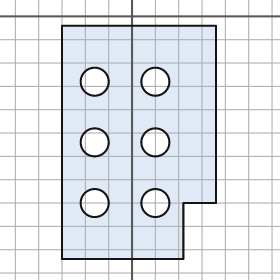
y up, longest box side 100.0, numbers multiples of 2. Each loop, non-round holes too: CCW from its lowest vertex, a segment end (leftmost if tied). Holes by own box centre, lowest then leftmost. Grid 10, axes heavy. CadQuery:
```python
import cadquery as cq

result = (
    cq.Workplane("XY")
    .moveTo(-30.0, -104.0)
    .lineTo(22.0, -104.0)
    .lineTo(22.0, -80.0)
    .lineTo(36.0, -80.0)
    .lineTo(36.0, -4.0)
    .lineTo(-30.0, -4.0)
    .close()
    .moveTo(-16.0, -80.0)
    .circle(6.0)
    .moveTo(10.0, -80.0)
    .circle(6.0)
    .moveTo(-16.0, -54.0)
    .circle(6.0)
    .moveTo(10.0, -54.0)
    .circle(6.0)
    .moveTo(-16.0, -28.0)
    .circle(6.0)
    .moveTo(10.0, -28.0)
    .circle(6.0)
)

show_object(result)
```